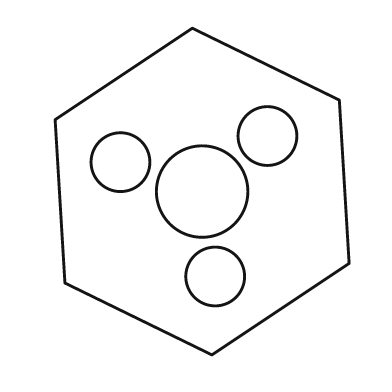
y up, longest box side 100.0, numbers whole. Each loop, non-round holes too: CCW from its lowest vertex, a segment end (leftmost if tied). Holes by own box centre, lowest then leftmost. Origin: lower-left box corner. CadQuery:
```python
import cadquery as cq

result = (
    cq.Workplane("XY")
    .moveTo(48.0, 0.0)
    .lineTo(90.0, 28.0)
    .lineTo(87.0, 78.0)
    .lineTo(42.0, 100.0)
    .lineTo(0.0, 72.0)
    .lineTo(3.0, 22.0)
    .close()
    .moveTo(49.0, 24.0)
    .circle(9.0)
    .moveTo(45.0, 50.0)
    .circle(14.0)
    .moveTo(20.0, 59.0)
    .circle(9.0)
    .moveTo(65.0, 67.0)
    .circle(9.0)
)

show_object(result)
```